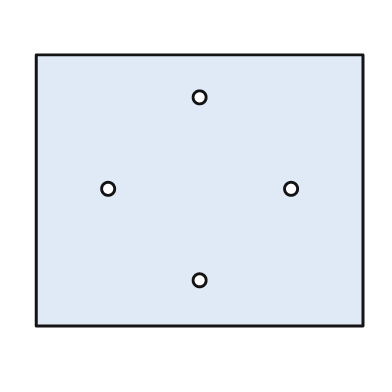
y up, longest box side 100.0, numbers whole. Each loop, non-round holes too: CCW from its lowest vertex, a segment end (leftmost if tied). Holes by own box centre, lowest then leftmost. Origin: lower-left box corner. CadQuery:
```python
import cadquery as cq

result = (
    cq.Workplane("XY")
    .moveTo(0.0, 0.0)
    .lineTo(100.0, 0.0)
    .lineTo(100.0, 83.0)
    .lineTo(0.0, 83.0)
    .close()
    .moveTo(50.0, 14.0)
    .circle(2.0)
    .moveTo(22.0, 42.0)
    .circle(2.0)
    .moveTo(78.0, 42.0)
    .circle(2.0)
    .moveTo(50.0, 70.0)
    .circle(2.0)
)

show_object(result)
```